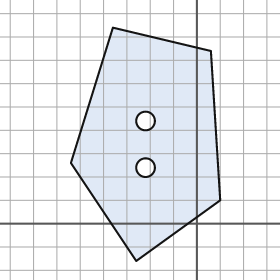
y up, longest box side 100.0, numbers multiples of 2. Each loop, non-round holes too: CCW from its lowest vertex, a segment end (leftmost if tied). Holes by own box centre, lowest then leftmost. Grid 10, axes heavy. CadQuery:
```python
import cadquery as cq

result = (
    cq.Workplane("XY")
    .moveTo(-26.0, -16.0)
    .lineTo(10.0, 10.0)
    .lineTo(6.0, 74.0)
    .lineTo(-36.0, 84.0)
    .lineTo(-54.0, 26.0)
    .close()
    .moveTo(-22.0, 24.0)
    .circle(4.0)
    .moveTo(-22.0, 44.0)
    .circle(4.0)
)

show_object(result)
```